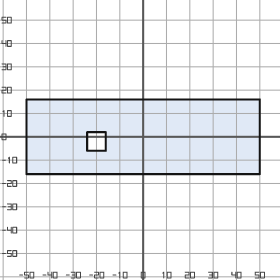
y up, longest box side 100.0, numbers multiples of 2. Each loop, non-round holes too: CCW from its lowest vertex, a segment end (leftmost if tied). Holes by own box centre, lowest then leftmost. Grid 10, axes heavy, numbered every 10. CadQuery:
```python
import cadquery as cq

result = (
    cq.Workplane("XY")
    .moveTo(-50.0, -16.0)
    .lineTo(50.0, -16.0)
    .lineTo(50.0, 16.0)
    .lineTo(-50.0, 16.0)
    .close()
    .moveTo(-24.0, -6.0)
    .lineTo(-16.0, -6.0)
    .lineTo(-16.0, 2.0)
    .lineTo(-24.0, 2.0)
    .close()
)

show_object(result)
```